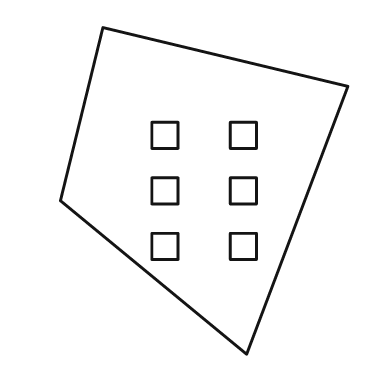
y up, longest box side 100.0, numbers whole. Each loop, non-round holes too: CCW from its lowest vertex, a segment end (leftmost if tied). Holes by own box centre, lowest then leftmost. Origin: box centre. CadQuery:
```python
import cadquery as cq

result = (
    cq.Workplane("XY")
    .moveTo(13.0, -50.0)
    .lineTo(44.0, 32.0)
    .lineTo(-31.0, 50.0)
    .lineTo(-44.0, -3.0)
    .close()
    .moveTo(-16.0, -21.0)
    .lineTo(-8.0, -21.0)
    .lineTo(-8.0, -13.0)
    .lineTo(-16.0, -13.0)
    .close()
    .moveTo(8.0, -21.0)
    .lineTo(16.0, -21.0)
    .lineTo(16.0, -13.0)
    .lineTo(8.0, -13.0)
    .close()
    .moveTo(-16.0, -4.0)
    .lineTo(-8.0, -4.0)
    .lineTo(-8.0, 4.0)
    .lineTo(-16.0, 4.0)
    .close()
    .moveTo(8.0, -4.0)
    .lineTo(16.0, -4.0)
    .lineTo(16.0, 4.0)
    .lineTo(8.0, 4.0)
    .close()
    .moveTo(-16.0, 13.0)
    .lineTo(-8.0, 13.0)
    .lineTo(-8.0, 21.0)
    .lineTo(-16.0, 21.0)
    .close()
    .moveTo(8.0, 13.0)
    .lineTo(16.0, 13.0)
    .lineTo(16.0, 21.0)
    .lineTo(8.0, 21.0)
    .close()
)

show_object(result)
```